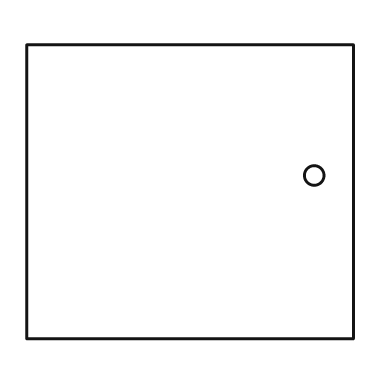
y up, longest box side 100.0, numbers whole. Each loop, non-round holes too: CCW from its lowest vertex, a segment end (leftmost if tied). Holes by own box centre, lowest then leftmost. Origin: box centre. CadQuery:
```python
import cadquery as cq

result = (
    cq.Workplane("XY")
    .moveTo(-50.0, -45.0)
    .lineTo(50.0, -45.0)
    .lineTo(50.0, 45.0)
    .lineTo(-50.0, 45.0)
    .close()
    .moveTo(38.0, 5.0)
    .circle(3.0)
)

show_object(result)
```